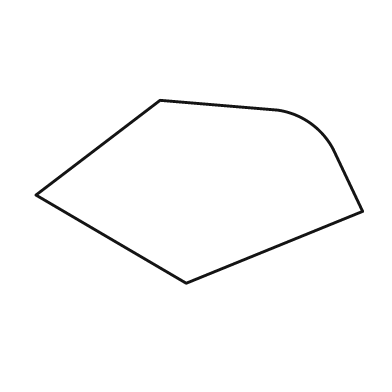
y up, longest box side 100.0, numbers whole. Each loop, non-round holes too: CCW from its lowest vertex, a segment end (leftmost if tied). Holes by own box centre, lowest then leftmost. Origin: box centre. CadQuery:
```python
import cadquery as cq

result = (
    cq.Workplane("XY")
    .moveTo(-4.0, -28.0)
    .lineTo(50.0, -6.0)
    .lineTo(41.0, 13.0)
    .threePointArc((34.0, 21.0), (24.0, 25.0))
    .lineTo(-12.0, 28.0)
    .lineTo(-50.0, -1.0)
    .close()
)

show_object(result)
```